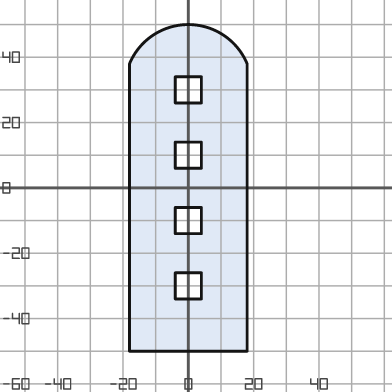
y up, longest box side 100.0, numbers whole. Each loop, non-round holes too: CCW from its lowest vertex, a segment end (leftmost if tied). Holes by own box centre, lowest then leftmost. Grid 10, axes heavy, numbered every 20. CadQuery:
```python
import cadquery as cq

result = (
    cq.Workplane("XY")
    .moveTo(-18.0, -50.0)
    .lineTo(18.0, -50.0)
    .lineTo(18.0, 38.0)
    .threePointArc((0.0, 50.0), (-18.0, 38.0))
    .close()
    .moveTo(-4.0, -34.0)
    .lineTo(4.0, -34.0)
    .lineTo(4.0, -26.0)
    .lineTo(-4.0, -26.0)
    .close()
    .moveTo(-4.0, -14.0)
    .lineTo(4.0, -14.0)
    .lineTo(4.0, -6.0)
    .lineTo(-4.0, -6.0)
    .close()
    .moveTo(-4.0, 6.0)
    .lineTo(4.0, 6.0)
    .lineTo(4.0, 14.0)
    .lineTo(-4.0, 14.0)
    .close()
    .moveTo(-4.0, 26.0)
    .lineTo(4.0, 26.0)
    .lineTo(4.0, 34.0)
    .lineTo(-4.0, 34.0)
    .close()
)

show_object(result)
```